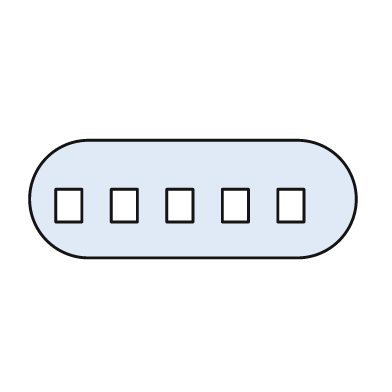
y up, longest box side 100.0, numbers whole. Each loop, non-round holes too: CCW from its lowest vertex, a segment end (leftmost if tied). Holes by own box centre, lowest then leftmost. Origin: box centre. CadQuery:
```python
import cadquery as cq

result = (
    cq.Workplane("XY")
    .moveTo(-32.0, -18.0)
    .lineTo(32.0, -18.0)
    .threePointArc((50.0, 0.0), (32.0, 18.0))
    .lineTo(-32.0, 18.0)
    .threePointArc((-50.0, 0.0), (-32.0, -18.0))
    .close()
    .moveTo(-42.0, -7.0)
    .lineTo(-34.0, -7.0)
    .lineTo(-34.0, 3.0)
    .lineTo(-42.0, 3.0)
    .close()
    .moveTo(-25.0, -7.0)
    .lineTo(-17.0, -7.0)
    .lineTo(-17.0, 3.0)
    .lineTo(-25.0, 3.0)
    .close()
    .moveTo(-8.0, -7.0)
    .lineTo(0.0, -7.0)
    .lineTo(0.0, 3.0)
    .lineTo(-8.0, 3.0)
    .close()
    .moveTo(9.0, -7.0)
    .lineTo(17.0, -7.0)
    .lineTo(17.0, 3.0)
    .lineTo(9.0, 3.0)
    .close()
    .moveTo(26.0, -7.0)
    .lineTo(34.0, -7.0)
    .lineTo(34.0, 3.0)
    .lineTo(26.0, 3.0)
    .close()
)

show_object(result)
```